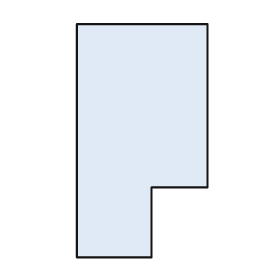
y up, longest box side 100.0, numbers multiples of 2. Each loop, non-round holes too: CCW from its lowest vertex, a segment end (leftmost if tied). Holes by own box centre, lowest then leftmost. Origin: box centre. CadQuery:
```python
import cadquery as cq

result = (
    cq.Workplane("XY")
    .moveTo(-28.0, -50.0)
    .lineTo(4.0, -50.0)
    .lineTo(4.0, -20.0)
    .lineTo(28.0, -20.0)
    .lineTo(28.0, 50.0)
    .lineTo(-28.0, 50.0)
    .close()
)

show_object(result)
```